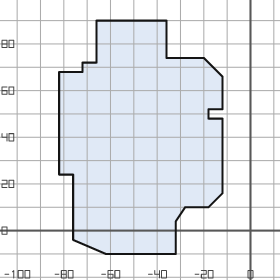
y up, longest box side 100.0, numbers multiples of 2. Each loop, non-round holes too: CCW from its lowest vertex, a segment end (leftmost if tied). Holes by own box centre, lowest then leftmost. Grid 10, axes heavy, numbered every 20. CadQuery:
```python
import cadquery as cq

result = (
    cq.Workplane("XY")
    .moveTo(-62.0, -10.0)
    .lineTo(-32.0, -10.0)
    .lineTo(-32.0, 4.0)
    .lineTo(-28.0, 10.0)
    .lineTo(-18.0, 10.0)
    .lineTo(-12.0, 16.0)
    .lineTo(-12.0, 48.0)
    .lineTo(-18.0, 48.0)
    .lineTo(-18.0, 52.0)
    .lineTo(-12.0, 52.0)
    .lineTo(-12.0, 66.0)
    .lineTo(-20.0, 74.0)
    .lineTo(-36.0, 74.0)
    .lineTo(-36.0, 90.0)
    .lineTo(-66.0, 90.0)
    .lineTo(-66.0, 72.0)
    .lineTo(-72.0, 72.0)
    .lineTo(-72.0, 68.0)
    .lineTo(-82.0, 68.0)
    .lineTo(-82.0, 24.0)
    .lineTo(-76.0, 24.0)
    .lineTo(-76.0, -4.0)
    .close()
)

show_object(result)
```